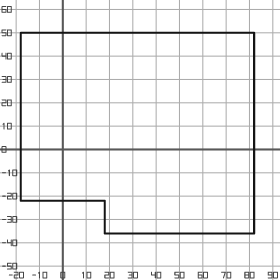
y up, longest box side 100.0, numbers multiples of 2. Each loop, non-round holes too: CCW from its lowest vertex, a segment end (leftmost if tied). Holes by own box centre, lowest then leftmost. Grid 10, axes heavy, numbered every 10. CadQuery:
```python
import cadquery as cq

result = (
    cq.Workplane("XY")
    .moveTo(18.0, -36.0)
    .lineTo(82.0, -36.0)
    .lineTo(82.0, 50.0)
    .lineTo(-18.0, 50.0)
    .lineTo(-18.0, -22.0)
    .lineTo(18.0, -22.0)
    .close()
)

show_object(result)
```